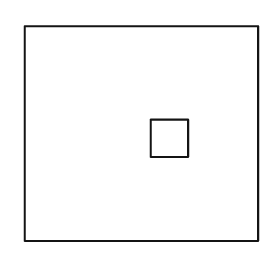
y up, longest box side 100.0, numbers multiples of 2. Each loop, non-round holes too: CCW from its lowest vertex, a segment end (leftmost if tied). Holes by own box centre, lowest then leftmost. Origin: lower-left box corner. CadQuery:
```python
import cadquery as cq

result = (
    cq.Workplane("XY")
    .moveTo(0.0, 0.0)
    .lineTo(100.0, 0.0)
    .lineTo(100.0, 92.0)
    .lineTo(0.0, 92.0)
    .close()
    .moveTo(54.0, 36.0)
    .lineTo(70.0, 36.0)
    .lineTo(70.0, 52.0)
    .lineTo(54.0, 52.0)
    .close()
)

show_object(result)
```